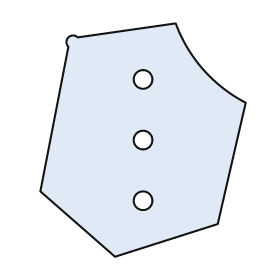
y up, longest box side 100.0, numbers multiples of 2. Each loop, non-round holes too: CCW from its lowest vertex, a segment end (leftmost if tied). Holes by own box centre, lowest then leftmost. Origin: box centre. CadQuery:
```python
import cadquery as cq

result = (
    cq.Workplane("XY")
    .moveTo(-12.0, -50.0)
    .lineTo(32.0, -36.0)
    .lineTo(44.0, 16.0)
    .threePointArc((26.0, 30.0), (14.0, 50.0))
    .lineTo(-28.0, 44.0)
    .threePointArc((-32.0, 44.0), (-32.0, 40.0))
    .lineTo(-44.0, -22.0)
    .close()
    .moveTo(0.0, -26.0)
    .circle(4.0)
    .moveTo(0.0, 0.0)
    .circle(4.0)
    .moveTo(0.0, 26.0)
    .circle(4.0)
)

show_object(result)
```